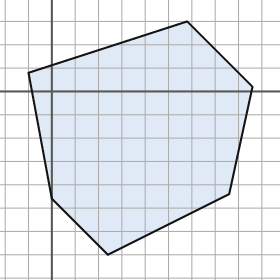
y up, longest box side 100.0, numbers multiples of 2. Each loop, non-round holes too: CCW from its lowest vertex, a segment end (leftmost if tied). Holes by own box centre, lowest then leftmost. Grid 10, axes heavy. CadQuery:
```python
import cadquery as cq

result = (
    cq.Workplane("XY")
    .moveTo(24.0, -70.0)
    .lineTo(76.0, -44.0)
    .lineTo(86.0, 2.0)
    .lineTo(58.0, 30.0)
    .lineTo(-10.0, 8.0)
    .lineTo(0.0, -46.0)
    .close()
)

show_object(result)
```